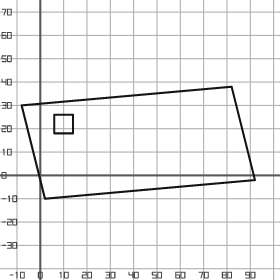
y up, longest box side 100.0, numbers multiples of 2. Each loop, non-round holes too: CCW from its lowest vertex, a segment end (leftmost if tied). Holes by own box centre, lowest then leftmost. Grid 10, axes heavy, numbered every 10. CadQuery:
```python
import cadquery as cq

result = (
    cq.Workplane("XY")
    .moveTo(2.0, -10.0)
    .lineTo(92.0, -2.0)
    .lineTo(82.0, 38.0)
    .lineTo(-8.0, 30.0)
    .close()
    .moveTo(6.0, 18.0)
    .lineTo(14.0, 18.0)
    .lineTo(14.0, 26.0)
    .lineTo(6.0, 26.0)
    .close()
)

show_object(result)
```